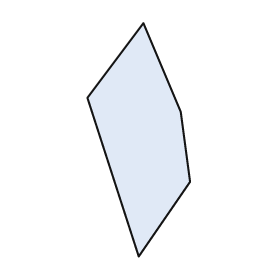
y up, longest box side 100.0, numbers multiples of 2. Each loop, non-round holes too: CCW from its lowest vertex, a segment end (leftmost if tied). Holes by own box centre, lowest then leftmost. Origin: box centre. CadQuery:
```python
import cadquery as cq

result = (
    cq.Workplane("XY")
    .moveTo(0.0, -50.0)
    .lineTo(22.0, -18.0)
    .lineTo(18.0, 12.0)
    .lineTo(2.0, 50.0)
    .lineTo(-22.0, 18.0)
    .close()
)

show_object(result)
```